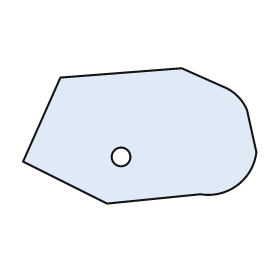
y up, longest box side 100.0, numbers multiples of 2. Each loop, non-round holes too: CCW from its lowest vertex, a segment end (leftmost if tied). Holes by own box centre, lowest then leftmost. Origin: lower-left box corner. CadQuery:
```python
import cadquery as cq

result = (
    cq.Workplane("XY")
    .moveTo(36.0, 0.0)
    .lineTo(76.0, 4.0)
    .threePointArc((92.0, 8.0), (100.0, 22.0))
    .lineTo(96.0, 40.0)
    .threePointArc((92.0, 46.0), (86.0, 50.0))
    .lineTo(68.0, 58.0)
    .lineTo(16.0, 54.0)
    .lineTo(0.0, 18.0)
    .close()
    .moveTo(42.0, 20.0)
    .circle(4.0)
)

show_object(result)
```